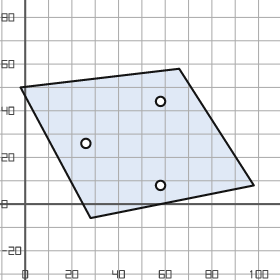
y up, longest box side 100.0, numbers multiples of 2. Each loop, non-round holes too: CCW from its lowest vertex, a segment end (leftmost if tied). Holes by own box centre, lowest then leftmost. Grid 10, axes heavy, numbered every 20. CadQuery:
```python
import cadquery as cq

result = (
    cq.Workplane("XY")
    .moveTo(28.0, -6.0)
    .lineTo(98.0, 8.0)
    .lineTo(66.0, 58.0)
    .lineTo(-2.0, 50.0)
    .close()
    .moveTo(58.0, 8.0)
    .circle(2.0)
    .moveTo(26.0, 26.0)
    .circle(2.0)
    .moveTo(58.0, 44.0)
    .circle(2.0)
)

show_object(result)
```